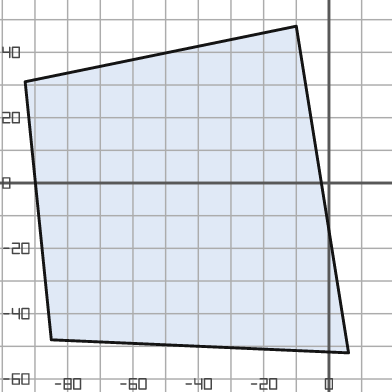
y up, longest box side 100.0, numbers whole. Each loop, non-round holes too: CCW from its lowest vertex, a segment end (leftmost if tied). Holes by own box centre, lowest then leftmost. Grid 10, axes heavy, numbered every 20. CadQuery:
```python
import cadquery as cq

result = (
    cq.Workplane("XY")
    .moveTo(6.0, -52.0)
    .lineTo(-10.0, 48.0)
    .lineTo(-93.0, 31.0)
    .lineTo(-85.0, -48.0)
    .close()
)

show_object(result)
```